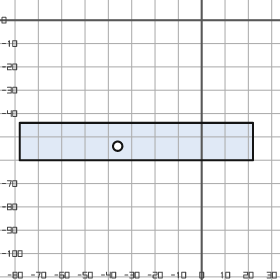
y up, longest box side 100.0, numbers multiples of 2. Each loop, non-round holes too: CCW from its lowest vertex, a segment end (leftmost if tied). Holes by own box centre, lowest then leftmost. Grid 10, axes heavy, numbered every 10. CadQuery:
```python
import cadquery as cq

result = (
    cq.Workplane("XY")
    .moveTo(-78.0, -60.0)
    .lineTo(22.0, -60.0)
    .lineTo(22.0, -44.0)
    .lineTo(-78.0, -44.0)
    .close()
    .moveTo(-36.0, -54.0)
    .circle(2.0)
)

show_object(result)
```